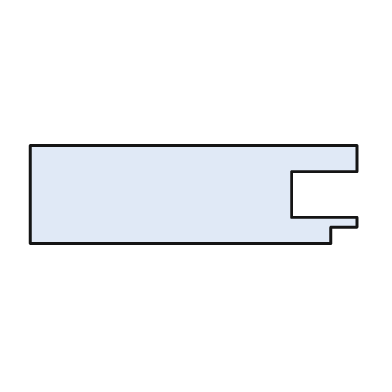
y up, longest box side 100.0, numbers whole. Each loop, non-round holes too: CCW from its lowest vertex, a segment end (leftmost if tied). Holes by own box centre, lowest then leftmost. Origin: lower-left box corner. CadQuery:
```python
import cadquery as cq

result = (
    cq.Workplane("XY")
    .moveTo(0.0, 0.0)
    .lineTo(92.0, 0.0)
    .lineTo(92.0, 5.0)
    .lineTo(100.0, 5.0)
    .lineTo(100.0, 8.0)
    .lineTo(80.0, 8.0)
    .lineTo(80.0, 22.0)
    .lineTo(100.0, 22.0)
    .lineTo(100.0, 30.0)
    .lineTo(0.0, 30.0)
    .close()
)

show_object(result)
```